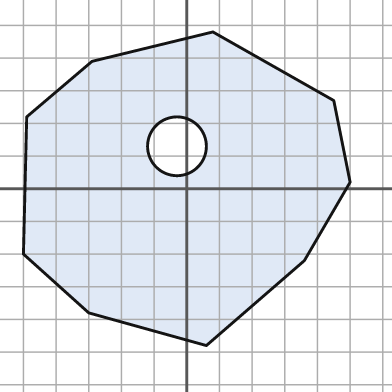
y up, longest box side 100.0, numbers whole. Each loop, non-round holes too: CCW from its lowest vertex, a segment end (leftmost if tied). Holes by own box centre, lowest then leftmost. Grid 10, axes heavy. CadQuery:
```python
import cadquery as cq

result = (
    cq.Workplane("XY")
    .moveTo(6.0, -48.0)
    .lineTo(36.0, -22.0)
    .lineTo(50.0, 2.0)
    .lineTo(45.0, 27.0)
    .lineTo(8.0, 48.0)
    .lineTo(-29.0, 39.0)
    .lineTo(-49.0, 22.0)
    .lineTo(-50.0, -20.0)
    .lineTo(-30.0, -38.0)
    .close()
    .moveTo(-3.0, 13.0)
    .circle(9.0)
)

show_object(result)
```